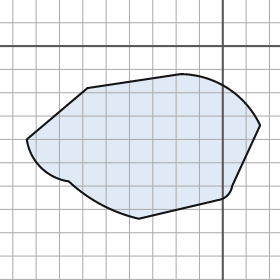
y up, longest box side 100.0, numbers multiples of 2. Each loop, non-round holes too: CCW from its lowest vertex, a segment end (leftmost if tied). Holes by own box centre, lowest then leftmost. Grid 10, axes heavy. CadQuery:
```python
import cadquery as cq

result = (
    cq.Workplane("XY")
    .moveTo(-36.0, -74.0)
    .lineTo(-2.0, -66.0)
    .threePointArc((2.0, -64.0), (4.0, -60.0))
    .lineTo(16.0, -34.0)
    .threePointArc((2.0, -18.0), (-18.0, -12.0))
    .lineTo(-58.0, -18.0)
    .lineTo(-84.0, -40.0)
    .threePointArc((-78.0, -52.0), (-66.0, -58.0))
    .threePointArc((-52.0, -68.0), (-36.0, -74.0))
    .close()
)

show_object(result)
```